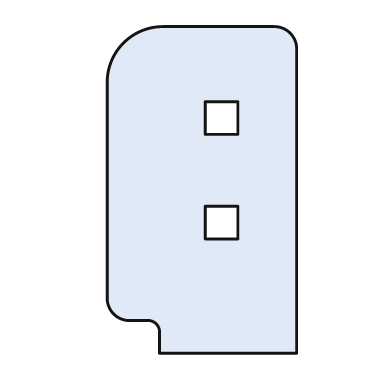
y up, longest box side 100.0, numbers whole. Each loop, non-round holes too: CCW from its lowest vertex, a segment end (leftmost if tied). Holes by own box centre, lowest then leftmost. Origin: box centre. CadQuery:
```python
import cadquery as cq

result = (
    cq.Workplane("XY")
    .moveTo(-13.0, -50.0)
    .lineTo(29.0, -50.0)
    .lineTo(29.0, 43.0)
    .threePointArc((27.0, 48.0), (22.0, 50.0))
    .lineTo(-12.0, 50.0)
    .threePointArc((-24.0, 45.0), (-29.0, 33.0))
    .lineTo(-29.0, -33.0)
    .threePointArc((-27.0, -38.0), (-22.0, -40.0))
    .lineTo(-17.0, -40.0)
    .threePointArc((-14.0, -41.0), (-13.0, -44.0))
    .close()
    .moveTo(1.0, -15.0)
    .lineTo(11.0, -15.0)
    .lineTo(11.0, -5.0)
    .lineTo(1.0, -5.0)
    .close()
    .moveTo(1.0, 17.0)
    .lineTo(11.0, 17.0)
    .lineTo(11.0, 27.0)
    .lineTo(1.0, 27.0)
    .close()
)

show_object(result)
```